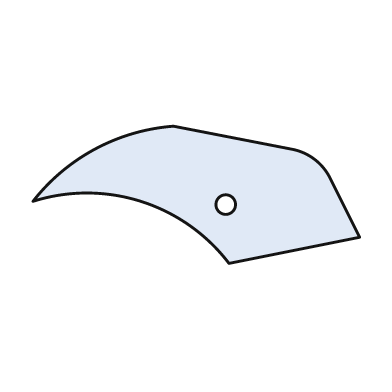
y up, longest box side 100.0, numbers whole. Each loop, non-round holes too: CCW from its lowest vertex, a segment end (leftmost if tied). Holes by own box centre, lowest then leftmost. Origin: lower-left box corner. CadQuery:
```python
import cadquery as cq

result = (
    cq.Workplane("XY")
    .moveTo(60.0, 0.0)
    .lineTo(100.0, 8.0)
    .lineTo(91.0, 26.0)
    .threePointArc((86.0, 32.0), (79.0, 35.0))
    .lineTo(43.0, 42.0)
    .threePointArc((19.0, 35.0), (0.0, 19.0))
    .threePointArc((33.0, 19.0), (60.0, 0.0))
    .close()
    .moveTo(59.0, 18.0)
    .circle(3.0)
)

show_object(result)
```